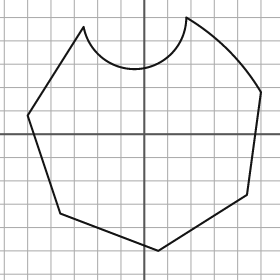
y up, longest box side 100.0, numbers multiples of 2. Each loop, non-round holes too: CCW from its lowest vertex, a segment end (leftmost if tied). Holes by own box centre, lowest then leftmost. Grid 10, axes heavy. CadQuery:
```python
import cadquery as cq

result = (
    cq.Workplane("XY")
    .moveTo(6.0, -50.0)
    .lineTo(44.0, -26.0)
    .lineTo(50.0, 18.0)
    .threePointArc((36.0, 36.0), (18.0, 50.0))
    .threePointArc((-2.0, 28.0), (-26.0, 46.0))
    .lineTo(-50.0, 8.0)
    .lineTo(-36.0, -34.0)
    .close()
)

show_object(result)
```